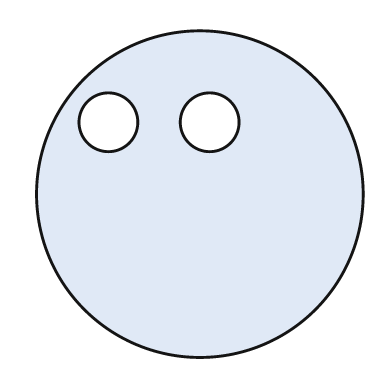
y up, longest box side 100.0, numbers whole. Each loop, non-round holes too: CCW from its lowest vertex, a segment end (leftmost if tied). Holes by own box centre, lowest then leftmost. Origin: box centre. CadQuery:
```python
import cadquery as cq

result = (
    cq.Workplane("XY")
    .moveTo(0.0, 0.0)
    .circle(50.0)
    .moveTo(-28.0, 22.0)
    .circle(9.0)
    .moveTo(3.0, 22.0)
    .circle(9.0)
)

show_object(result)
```